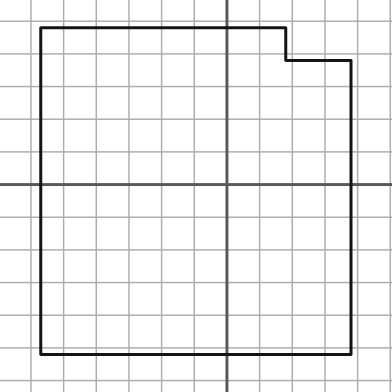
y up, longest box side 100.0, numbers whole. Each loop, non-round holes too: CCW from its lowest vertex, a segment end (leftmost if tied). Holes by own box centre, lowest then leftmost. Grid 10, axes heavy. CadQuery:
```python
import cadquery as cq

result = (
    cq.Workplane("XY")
    .moveTo(-57.0, -52.0)
    .lineTo(38.0, -52.0)
    .lineTo(38.0, 38.0)
    .lineTo(18.0, 38.0)
    .lineTo(18.0, 48.0)
    .lineTo(-57.0, 48.0)
    .close()
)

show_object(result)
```